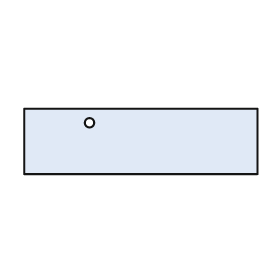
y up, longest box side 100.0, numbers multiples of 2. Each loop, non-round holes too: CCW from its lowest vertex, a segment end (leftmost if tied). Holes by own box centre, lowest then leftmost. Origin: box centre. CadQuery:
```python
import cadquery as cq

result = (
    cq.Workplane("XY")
    .moveTo(-50.0, -14.0)
    .lineTo(50.0, -14.0)
    .lineTo(50.0, 14.0)
    .lineTo(-50.0, 14.0)
    .close()
    .moveTo(-22.0, 8.0)
    .circle(2.0)
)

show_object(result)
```